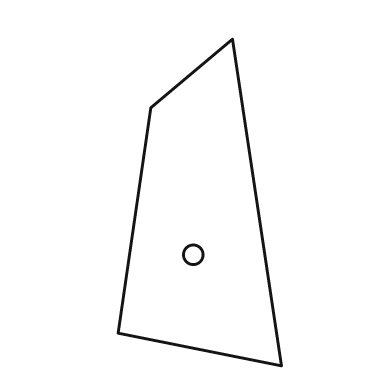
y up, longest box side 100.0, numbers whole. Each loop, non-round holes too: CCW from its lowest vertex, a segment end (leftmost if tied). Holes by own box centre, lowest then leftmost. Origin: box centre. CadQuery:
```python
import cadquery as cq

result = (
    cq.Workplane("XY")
    .moveTo(25.0, -50.0)
    .lineTo(10.0, 50.0)
    .lineTo(-15.0, 29.0)
    .lineTo(-25.0, -40.0)
    .close()
    .moveTo(-2.0, -16.0)
    .circle(3.0)
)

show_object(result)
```